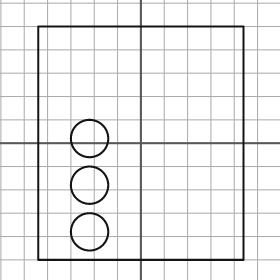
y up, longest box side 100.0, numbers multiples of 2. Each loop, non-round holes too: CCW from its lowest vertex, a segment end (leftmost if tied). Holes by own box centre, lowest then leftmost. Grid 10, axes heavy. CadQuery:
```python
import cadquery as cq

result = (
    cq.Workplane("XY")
    .moveTo(-44.0, -50.0)
    .lineTo(44.0, -50.0)
    .lineTo(44.0, 50.0)
    .lineTo(-44.0, 50.0)
    .close()
    .moveTo(-22.0, -38.0)
    .circle(8.0)
    .moveTo(-22.0, -18.0)
    .circle(8.0)
    .moveTo(-22.0, 2.0)
    .circle(8.0)
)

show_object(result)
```